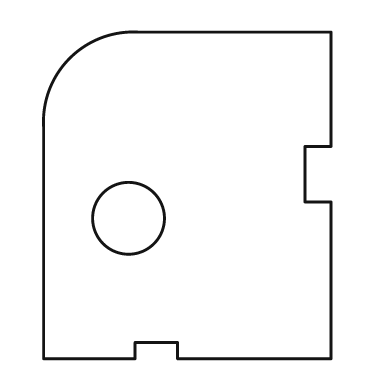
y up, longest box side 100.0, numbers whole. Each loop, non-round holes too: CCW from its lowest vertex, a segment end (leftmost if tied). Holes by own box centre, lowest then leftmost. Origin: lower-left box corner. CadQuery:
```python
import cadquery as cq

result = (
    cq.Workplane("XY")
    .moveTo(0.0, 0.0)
    .lineTo(28.0, 0.0)
    .lineTo(28.0, 5.0)
    .lineTo(41.0, 5.0)
    .lineTo(41.0, 0.0)
    .lineTo(88.0, 0.0)
    .lineTo(88.0, 48.0)
    .lineTo(80.0, 48.0)
    .lineTo(80.0, 65.0)
    .lineTo(88.0, 65.0)
    .lineTo(88.0, 100.0)
    .lineTo(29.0, 100.0)
    .threePointArc((8.0, 92.0), (0.0, 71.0))
    .close()
    .moveTo(26.0, 43.0)
    .circle(11.0)
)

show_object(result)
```